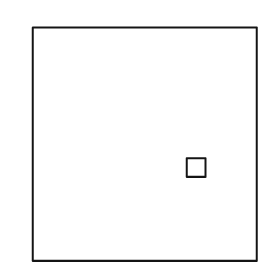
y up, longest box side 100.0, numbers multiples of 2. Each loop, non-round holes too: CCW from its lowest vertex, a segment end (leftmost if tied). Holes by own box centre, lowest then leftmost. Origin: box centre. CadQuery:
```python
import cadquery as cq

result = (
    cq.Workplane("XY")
    .moveTo(-48.0, -50.0)
    .lineTo(48.0, -50.0)
    .lineTo(48.0, 50.0)
    .lineTo(-48.0, 50.0)
    .close()
    .moveTo(18.0, -14.0)
    .lineTo(26.0, -14.0)
    .lineTo(26.0, -6.0)
    .lineTo(18.0, -6.0)
    .close()
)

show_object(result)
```